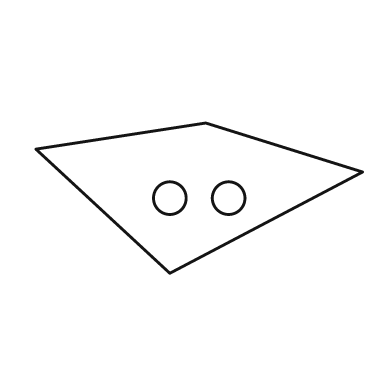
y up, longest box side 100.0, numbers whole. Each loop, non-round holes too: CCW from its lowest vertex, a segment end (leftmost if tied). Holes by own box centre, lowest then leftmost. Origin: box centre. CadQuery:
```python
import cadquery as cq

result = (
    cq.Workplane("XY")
    .moveTo(-9.0, -23.0)
    .lineTo(50.0, 8.0)
    .lineTo(2.0, 23.0)
    .lineTo(-50.0, 15.0)
    .close()
    .moveTo(-9.0, 0.0)
    .circle(5.0)
    .moveTo(9.0, 0.0)
    .circle(5.0)
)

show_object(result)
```